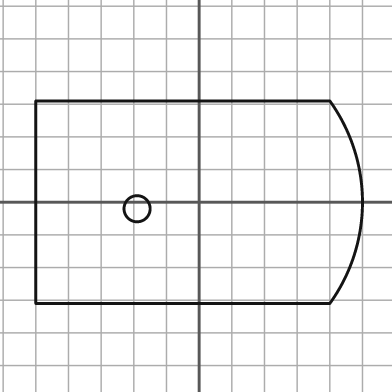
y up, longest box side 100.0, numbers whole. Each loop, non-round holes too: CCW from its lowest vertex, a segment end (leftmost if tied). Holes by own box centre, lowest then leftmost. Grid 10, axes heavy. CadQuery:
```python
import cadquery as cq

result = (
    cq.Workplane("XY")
    .moveTo(-50.0, -31.0)
    .lineTo(40.0, -31.0)
    .threePointArc((50.0, 0.0), (40.0, 31.0))
    .lineTo(-50.0, 31.0)
    .close()
    .moveTo(-19.0, -2.0)
    .circle(4.0)
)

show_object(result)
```